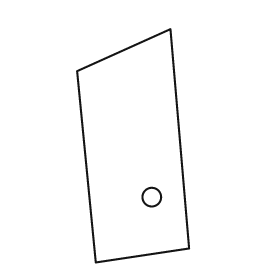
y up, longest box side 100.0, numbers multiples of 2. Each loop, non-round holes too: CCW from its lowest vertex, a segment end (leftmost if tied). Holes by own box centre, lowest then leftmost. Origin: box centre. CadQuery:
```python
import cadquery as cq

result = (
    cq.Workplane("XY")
    .moveTo(-16.0, -50.0)
    .lineTo(24.0, -44.0)
    .lineTo(16.0, 50.0)
    .lineTo(-24.0, 32.0)
    .close()
    .moveTo(8.0, -22.0)
    .circle(4.0)
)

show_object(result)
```